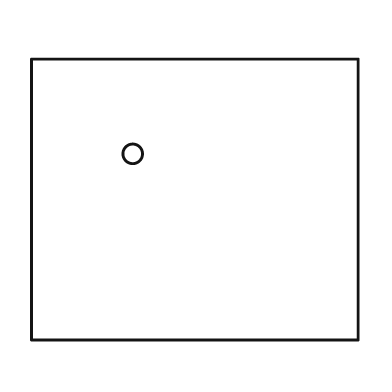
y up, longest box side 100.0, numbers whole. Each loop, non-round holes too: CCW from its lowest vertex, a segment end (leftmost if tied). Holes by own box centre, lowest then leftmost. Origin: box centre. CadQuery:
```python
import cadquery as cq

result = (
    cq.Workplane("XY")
    .moveTo(-50.0, -43.0)
    .lineTo(50.0, -43.0)
    .lineTo(50.0, 43.0)
    .lineTo(-50.0, 43.0)
    .close()
    .moveTo(-19.0, 14.0)
    .circle(3.0)
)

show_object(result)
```